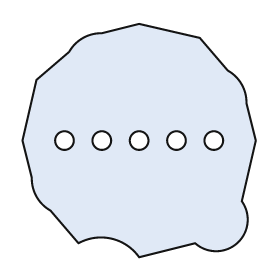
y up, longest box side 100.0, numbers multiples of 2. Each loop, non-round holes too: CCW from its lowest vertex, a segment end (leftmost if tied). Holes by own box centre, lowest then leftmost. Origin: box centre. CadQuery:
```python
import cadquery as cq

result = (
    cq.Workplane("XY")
    .moveTo(0.0, -50.0)
    .lineTo(24.0, -44.0)
    .threePointArc((42.0, -44.0), (44.0, -26.0))
    .lineTo(50.0, 0.0)
    .lineTo(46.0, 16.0)
    .threePointArc((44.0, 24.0), (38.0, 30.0))
    .lineTo(26.0, 44.0)
    .lineTo(0.0, 50.0)
    .lineTo(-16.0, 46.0)
    .threePointArc((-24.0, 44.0), (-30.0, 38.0))
    .lineTo(-44.0, 26.0)
    .lineTo(-50.0, 0.0)
    .lineTo(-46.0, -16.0)
    .threePointArc((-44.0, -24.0), (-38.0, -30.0))
    .lineTo(-26.0, -44.0)
    .threePointArc((-12.0, -42.0), (0.0, -50.0))
    .close()
    .moveTo(-32.0, 0.0)
    .circle(4.0)
    .moveTo(-16.0, 0.0)
    .circle(4.0)
    .moveTo(0.0, 0.0)
    .circle(4.0)
    .moveTo(16.0, 0.0)
    .circle(4.0)
    .moveTo(32.0, 0.0)
    .circle(4.0)
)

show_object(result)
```